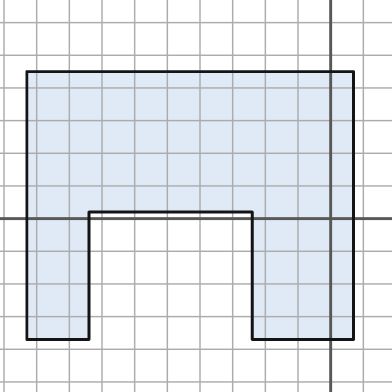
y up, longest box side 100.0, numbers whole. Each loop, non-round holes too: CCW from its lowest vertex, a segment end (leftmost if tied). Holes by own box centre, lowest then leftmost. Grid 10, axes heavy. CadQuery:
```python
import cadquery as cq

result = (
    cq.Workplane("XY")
    .moveTo(-93.0, -37.0)
    .lineTo(-74.0, -37.0)
    .lineTo(-74.0, 2.0)
    .lineTo(-24.0, 2.0)
    .lineTo(-24.0, -37.0)
    .lineTo(7.0, -37.0)
    .lineTo(7.0, 45.0)
    .lineTo(-93.0, 45.0)
    .close()
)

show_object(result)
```